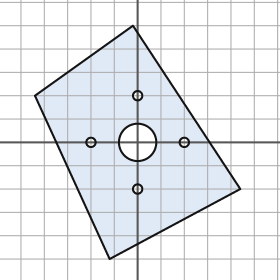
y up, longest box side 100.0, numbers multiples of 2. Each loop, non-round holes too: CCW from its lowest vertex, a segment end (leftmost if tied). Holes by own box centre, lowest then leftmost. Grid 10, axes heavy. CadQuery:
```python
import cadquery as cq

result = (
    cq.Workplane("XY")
    .moveTo(-12.0, -50.0)
    .lineTo(44.0, -20.0)
    .lineTo(-2.0, 50.0)
    .lineTo(-44.0, 20.0)
    .close()
    .moveTo(0.0, -20.0)
    .circle(2.0)
    .moveTo(-20.0, 0.0)
    .circle(2.0)
    .moveTo(0.0, 0.0)
    .circle(8.0)
    .moveTo(20.0, 0.0)
    .circle(2.0)
    .moveTo(0.0, 20.0)
    .circle(2.0)
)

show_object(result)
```